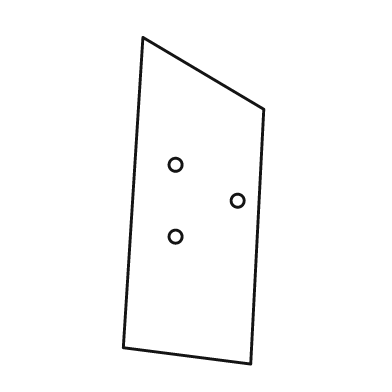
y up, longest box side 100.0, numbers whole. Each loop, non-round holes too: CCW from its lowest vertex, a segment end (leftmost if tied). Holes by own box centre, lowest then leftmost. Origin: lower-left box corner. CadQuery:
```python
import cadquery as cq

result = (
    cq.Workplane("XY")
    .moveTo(39.0, 0.0)
    .lineTo(43.0, 78.0)
    .lineTo(6.0, 100.0)
    .lineTo(0.0, 5.0)
    .close()
    .moveTo(16.0, 39.0)
    .circle(2.0)
    .moveTo(35.0, 50.0)
    .circle(2.0)
    .moveTo(16.0, 61.0)
    .circle(2.0)
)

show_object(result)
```